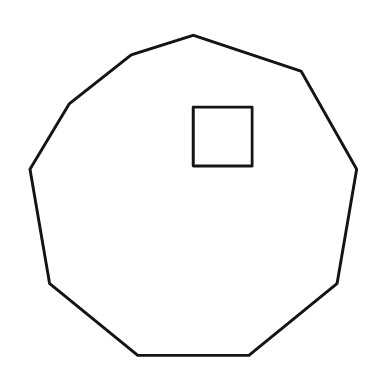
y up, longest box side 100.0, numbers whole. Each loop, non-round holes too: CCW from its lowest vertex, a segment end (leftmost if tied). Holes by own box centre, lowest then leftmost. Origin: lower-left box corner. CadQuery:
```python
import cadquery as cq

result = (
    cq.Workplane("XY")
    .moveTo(33.0, 0.0)
    .lineTo(67.0, 0.0)
    .lineTo(94.0, 22.0)
    .lineTo(100.0, 57.0)
    .lineTo(83.0, 87.0)
    .lineTo(50.0, 98.0)
    .lineTo(31.0, 92.0)
    .lineTo(12.0, 77.0)
    .lineTo(0.0, 57.0)
    .lineTo(6.0, 22.0)
    .close()
    .moveTo(50.0, 58.0)
    .lineTo(68.0, 58.0)
    .lineTo(68.0, 76.0)
    .lineTo(50.0, 76.0)
    .close()
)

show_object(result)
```